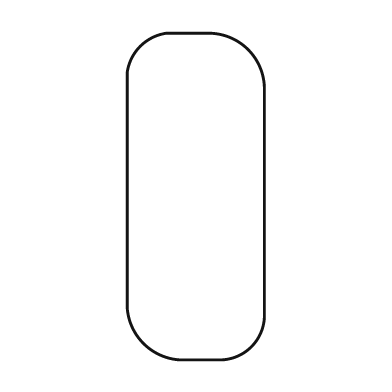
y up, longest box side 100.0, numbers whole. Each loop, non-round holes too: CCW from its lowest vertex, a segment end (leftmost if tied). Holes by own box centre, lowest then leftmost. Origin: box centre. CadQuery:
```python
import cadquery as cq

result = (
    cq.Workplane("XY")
    .moveTo(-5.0, -50.0)
    .lineTo(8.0, -50.0)
    .threePointArc((17.0, -46.0), (21.0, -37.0))
    .lineTo(21.0, 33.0)
    .threePointArc((16.0, 45.0), (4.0, 50.0))
    .lineTo(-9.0, 50.0)
    .threePointArc((-17.0, 46.0), (-21.0, 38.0))
    .lineTo(-21.0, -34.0)
    .threePointArc((-16.0, -45.0), (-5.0, -50.0))
    .close()
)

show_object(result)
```